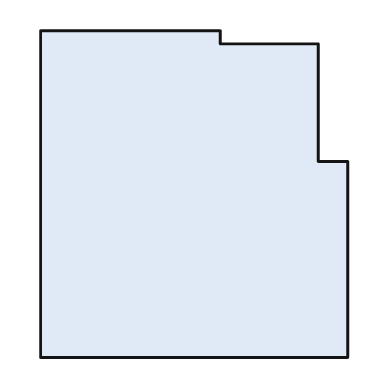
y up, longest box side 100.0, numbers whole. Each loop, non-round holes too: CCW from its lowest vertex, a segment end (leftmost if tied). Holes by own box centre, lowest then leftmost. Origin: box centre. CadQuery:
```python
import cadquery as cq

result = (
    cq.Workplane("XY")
    .moveTo(-47.0, -50.0)
    .lineTo(47.0, -50.0)
    .lineTo(47.0, 10.0)
    .lineTo(38.0, 10.0)
    .lineTo(38.0, 46.0)
    .lineTo(8.0, 46.0)
    .lineTo(8.0, 50.0)
    .lineTo(-47.0, 50.0)
    .close()
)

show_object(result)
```